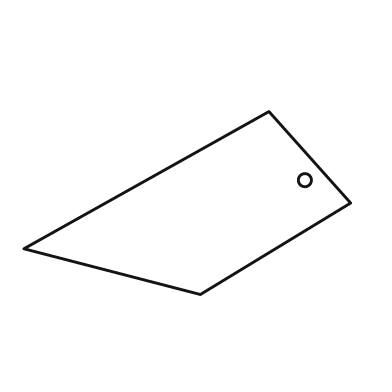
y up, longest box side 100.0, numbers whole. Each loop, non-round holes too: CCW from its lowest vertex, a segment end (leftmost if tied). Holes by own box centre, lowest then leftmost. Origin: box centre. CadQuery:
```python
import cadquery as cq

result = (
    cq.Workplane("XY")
    .moveTo(4.0, -28.0)
    .lineTo(50.0, 0.0)
    .lineTo(25.0, 28.0)
    .lineTo(-50.0, -14.0)
    .close()
    .moveTo(36.0, 7.0)
    .circle(2.0)
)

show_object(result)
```